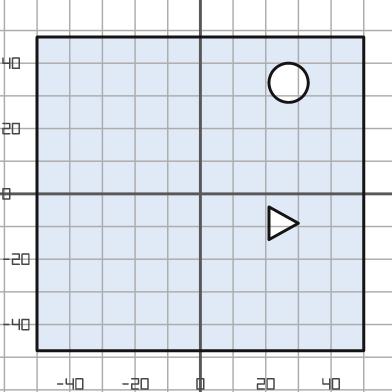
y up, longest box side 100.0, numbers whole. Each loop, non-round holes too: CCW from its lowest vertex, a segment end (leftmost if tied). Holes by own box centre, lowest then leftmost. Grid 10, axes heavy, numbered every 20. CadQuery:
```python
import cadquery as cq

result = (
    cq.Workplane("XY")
    .moveTo(-50.0, -48.0)
    .lineTo(50.0, -48.0)
    .lineTo(50.0, 48.0)
    .lineTo(-50.0, 48.0)
    .close()
    .moveTo(21.0, -14.0)
    .lineTo(30.0, -9.0)
    .lineTo(21.0, -4.0)
    .close()
    .moveTo(27.0, 34.0)
    .circle(6.0)
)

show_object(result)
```